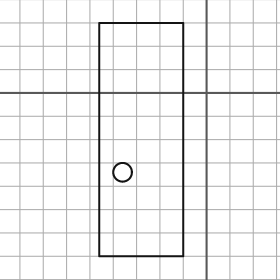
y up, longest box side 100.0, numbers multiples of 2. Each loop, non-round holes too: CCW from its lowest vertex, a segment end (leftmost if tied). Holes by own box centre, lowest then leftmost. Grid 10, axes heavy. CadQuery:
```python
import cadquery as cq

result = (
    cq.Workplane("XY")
    .moveTo(-46.0, -70.0)
    .lineTo(-10.0, -70.0)
    .lineTo(-10.0, 30.0)
    .lineTo(-46.0, 30.0)
    .close()
    .moveTo(-36.0, -34.0)
    .circle(4.0)
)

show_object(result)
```